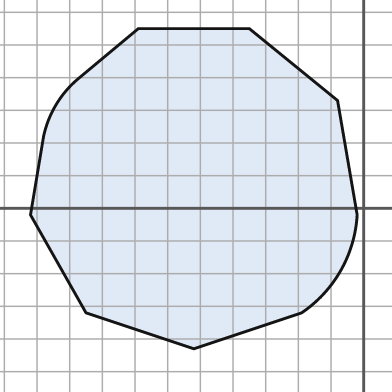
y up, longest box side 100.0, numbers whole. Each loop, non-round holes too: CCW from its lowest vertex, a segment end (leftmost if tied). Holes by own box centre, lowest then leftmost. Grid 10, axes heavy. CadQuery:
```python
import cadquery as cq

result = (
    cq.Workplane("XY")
    .moveTo(-52.0, -43.0)
    .lineTo(-19.0, -32.0)
    .threePointArc((-7.0, -19.0), (-2.0, -2.0))
    .lineTo(-8.0, 33.0)
    .lineTo(-35.0, 55.0)
    .lineTo(-69.0, 55.0)
    .lineTo(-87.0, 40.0)
    .threePointArc((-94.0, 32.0), (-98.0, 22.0))
    .lineTo(-102.0, -2.0)
    .lineTo(-85.0, -32.0)
    .close()
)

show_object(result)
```